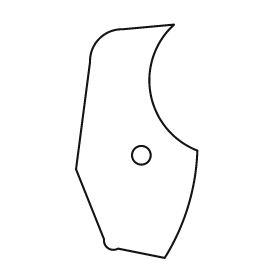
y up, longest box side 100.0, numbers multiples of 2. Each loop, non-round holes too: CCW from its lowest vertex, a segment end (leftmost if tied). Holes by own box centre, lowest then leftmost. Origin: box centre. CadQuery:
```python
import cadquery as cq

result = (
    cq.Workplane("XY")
    .moveTo(12.0, -50.0)
    .threePointArc((22.0, -28.0), (26.0, -4.0))
    .threePointArc((6.0, 20.0), (16.0, 50.0))
    .lineTo(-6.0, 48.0)
    .threePointArc((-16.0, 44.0), (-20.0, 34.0))
    .lineTo(-26.0, -12.0)
    .lineTo(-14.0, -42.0)
    .threePointArc((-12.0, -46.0), (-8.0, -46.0))
    .close()
    .moveTo(2.0, -6.0)
    .circle(4.0)
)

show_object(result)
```